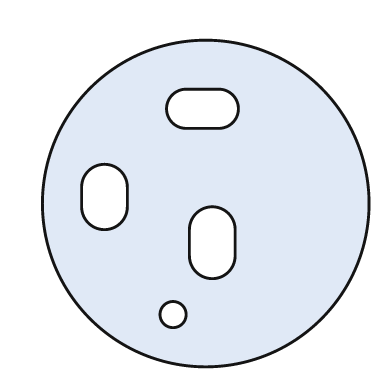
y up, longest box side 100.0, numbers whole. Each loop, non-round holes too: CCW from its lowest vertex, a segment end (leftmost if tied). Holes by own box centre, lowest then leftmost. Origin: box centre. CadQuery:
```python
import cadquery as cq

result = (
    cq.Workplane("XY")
    .moveTo(0.0, 0.0)
    .circle(50.0)
    .moveTo(-10.0, -34.0)
    .circle(4.0)
    .moveTo(-5.0, -16.0)
    .threePointArc((2.0, -23.0), (9.0, -16.0))
    .lineTo(9.0, -8.0)
    .threePointArc((2.0, -1.0), (-5.0, -8.0))
    .close()
    .moveTo(-38.0, -1.0)
    .threePointArc((-31.0, -8.0), (-24.0, -1.0))
    .lineTo(-24.0, 5.0)
    .threePointArc((-31.0, 12.0), (-38.0, 5.0))
    .close()
    .moveTo(-6.0, 23.0)
    .lineTo(4.0, 23.0)
    .threePointArc((10.0, 29.0), (4.0, 35.0))
    .lineTo(-6.0, 35.0)
    .threePointArc((-12.0, 29.0), (-6.0, 23.0))
    .close()
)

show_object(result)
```